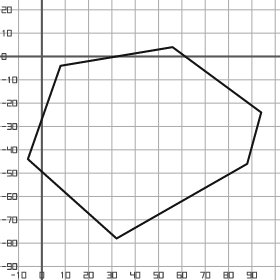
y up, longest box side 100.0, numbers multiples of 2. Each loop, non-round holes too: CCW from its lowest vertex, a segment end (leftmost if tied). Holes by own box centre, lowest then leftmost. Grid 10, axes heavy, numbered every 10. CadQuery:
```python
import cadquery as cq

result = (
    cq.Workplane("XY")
    .moveTo(32.0, -78.0)
    .lineTo(88.0, -46.0)
    .lineTo(94.0, -24.0)
    .lineTo(56.0, 4.0)
    .lineTo(8.0, -4.0)
    .lineTo(-6.0, -44.0)
    .close()
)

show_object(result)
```